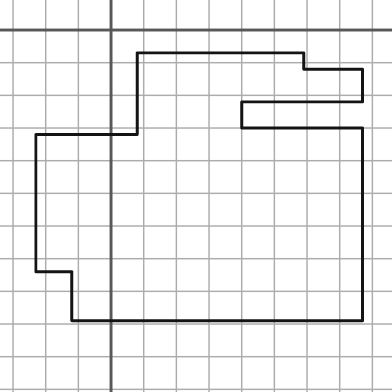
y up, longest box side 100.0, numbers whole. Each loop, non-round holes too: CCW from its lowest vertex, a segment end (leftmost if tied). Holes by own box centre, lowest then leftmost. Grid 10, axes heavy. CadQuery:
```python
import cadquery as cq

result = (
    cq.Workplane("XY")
    .moveTo(-12.0, -89.0)
    .lineTo(77.0, -89.0)
    .lineTo(77.0, -30.0)
    .lineTo(40.0, -30.0)
    .lineTo(40.0, -22.0)
    .lineTo(77.0, -22.0)
    .lineTo(77.0, -12.0)
    .lineTo(59.0, -12.0)
    .lineTo(59.0, -7.0)
    .lineTo(8.0, -7.0)
    .lineTo(8.0, -32.0)
    .lineTo(-23.0, -32.0)
    .lineTo(-23.0, -74.0)
    .lineTo(-12.0, -74.0)
    .close()
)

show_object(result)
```